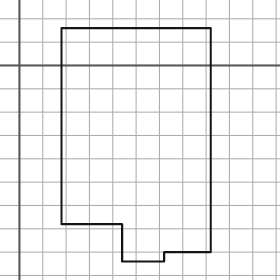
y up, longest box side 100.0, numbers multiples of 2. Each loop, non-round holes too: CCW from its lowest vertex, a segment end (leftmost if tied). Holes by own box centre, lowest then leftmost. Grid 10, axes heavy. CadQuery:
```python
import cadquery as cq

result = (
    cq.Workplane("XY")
    .moveTo(44.0, -84.0)
    .lineTo(62.0, -84.0)
    .lineTo(62.0, -80.0)
    .lineTo(82.0, -80.0)
    .lineTo(82.0, 16.0)
    .lineTo(18.0, 16.0)
    .lineTo(18.0, -68.0)
    .lineTo(44.0, -68.0)
    .close()
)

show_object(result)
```